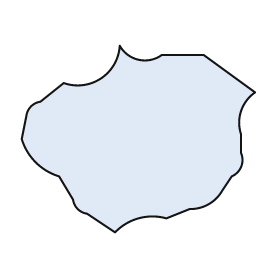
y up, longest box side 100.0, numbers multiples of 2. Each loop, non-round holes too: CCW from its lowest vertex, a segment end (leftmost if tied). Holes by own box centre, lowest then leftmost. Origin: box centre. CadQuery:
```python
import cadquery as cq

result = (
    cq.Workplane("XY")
    .moveTo(-10.0, -40.0)
    .threePointArc((0.0, -34.0), (12.0, -34.0))
    .lineTo(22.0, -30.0)
    .threePointArc((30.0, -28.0), (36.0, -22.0))
    .lineTo(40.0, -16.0)
    .threePointArc((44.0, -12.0), (44.0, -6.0))
    .lineTo(44.0, 2.0)
    .threePointArc((44.0, 12.0), (50.0, 20.0))
    .lineTo(28.0, 36.0)
    .lineTo(10.0, 36.0)
    .threePointArc((0.0, 34.0), (-8.0, 40.0))
    .threePointArc((-16.0, 26.0), (-32.0, 24.0))
    .lineTo(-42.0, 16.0)
    .threePointArc((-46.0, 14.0), (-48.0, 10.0))
    .lineTo(-50.0, 0.0)
    .threePointArc((-44.0, -10.0), (-34.0, -16.0))
    .lineTo(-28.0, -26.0)
    .threePointArc((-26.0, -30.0), (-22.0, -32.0))
    .close()
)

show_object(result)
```